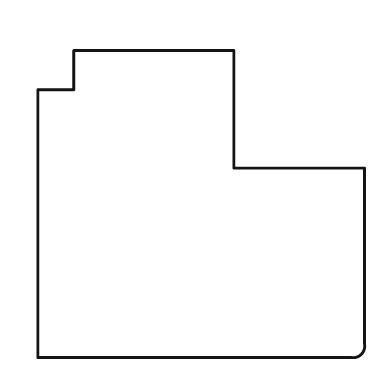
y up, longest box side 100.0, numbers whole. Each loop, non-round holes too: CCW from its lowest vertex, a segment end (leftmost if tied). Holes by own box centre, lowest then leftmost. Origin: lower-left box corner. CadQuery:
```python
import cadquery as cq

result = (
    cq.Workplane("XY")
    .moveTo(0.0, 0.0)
    .lineTo(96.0, 0.0)
    .threePointArc((99.0, 1.0), (100.0, 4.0))
    .lineTo(100.0, 58.0)
    .lineTo(60.0, 58.0)
    .lineTo(60.0, 94.0)
    .lineTo(11.0, 94.0)
    .lineTo(11.0, 82.0)
    .lineTo(0.0, 82.0)
    .close()
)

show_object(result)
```